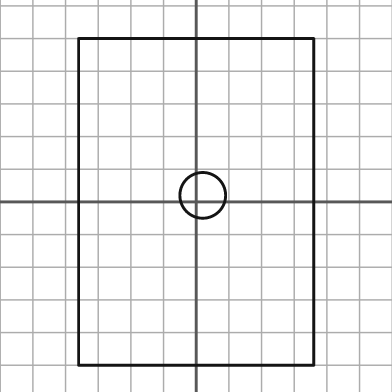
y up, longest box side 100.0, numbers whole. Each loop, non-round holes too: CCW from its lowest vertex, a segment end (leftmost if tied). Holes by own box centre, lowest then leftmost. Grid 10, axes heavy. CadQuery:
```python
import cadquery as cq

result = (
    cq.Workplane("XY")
    .moveTo(-36.0, -50.0)
    .lineTo(36.0, -50.0)
    .lineTo(36.0, 50.0)
    .lineTo(-36.0, 50.0)
    .close()
    .moveTo(2.0, 2.0)
    .circle(7.0)
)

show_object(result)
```